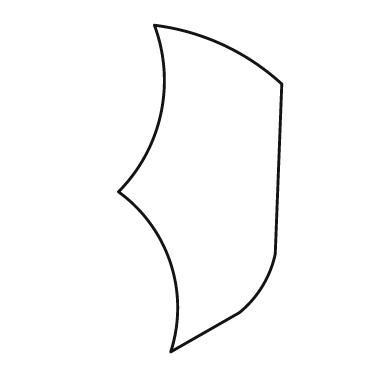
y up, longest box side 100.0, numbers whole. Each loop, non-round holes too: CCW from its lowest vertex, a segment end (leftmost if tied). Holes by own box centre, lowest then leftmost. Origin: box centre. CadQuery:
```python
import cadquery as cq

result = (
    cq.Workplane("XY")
    .moveTo(-9.0, -50.0)
    .lineTo(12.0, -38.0)
    .threePointArc((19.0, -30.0), (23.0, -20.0))
    .lineTo(25.0, 32.0)
    .threePointArc((7.0, 44.0), (-14.0, 50.0))
    .threePointArc((-12.0, 23.0), (-25.0, -1.0))
    .threePointArc((-9.0, -23.0), (-9.0, -50.0))
    .close()
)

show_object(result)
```